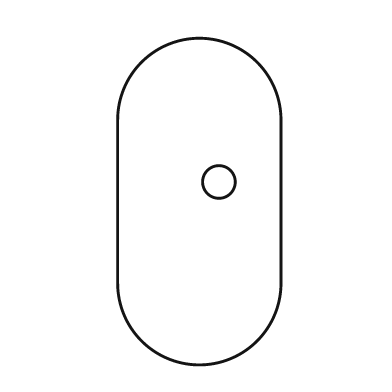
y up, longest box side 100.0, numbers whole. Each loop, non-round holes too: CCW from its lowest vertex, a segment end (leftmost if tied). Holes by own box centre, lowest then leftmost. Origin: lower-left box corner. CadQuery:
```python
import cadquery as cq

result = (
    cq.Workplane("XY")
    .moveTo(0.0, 25.0)
    .threePointArc((25.0, 0.0), (50.0, 25.0))
    .lineTo(50.0, 75.0)
    .threePointArc((25.0, 100.0), (0.0, 75.0))
    .close()
    .moveTo(31.0, 56.0)
    .circle(5.0)
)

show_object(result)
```